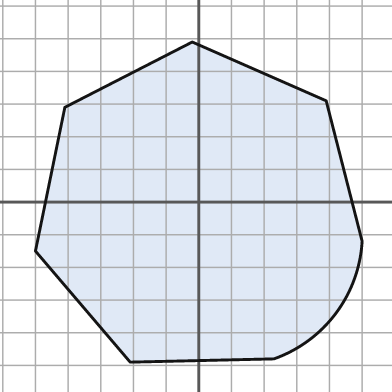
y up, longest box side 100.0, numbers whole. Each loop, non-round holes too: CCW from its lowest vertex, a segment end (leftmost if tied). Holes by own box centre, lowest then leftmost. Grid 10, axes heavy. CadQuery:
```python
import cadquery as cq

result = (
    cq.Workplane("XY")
    .moveTo(-21.0, -49.0)
    .lineTo(23.0, -48.0)
    .threePointArc((42.0, -34.0), (50.0, -12.0))
    .lineTo(39.0, 31.0)
    .lineTo(-2.0, 49.0)
    .lineTo(-41.0, 29.0)
    .lineTo(-50.0, -15.0)
    .close()
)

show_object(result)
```